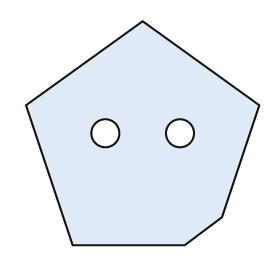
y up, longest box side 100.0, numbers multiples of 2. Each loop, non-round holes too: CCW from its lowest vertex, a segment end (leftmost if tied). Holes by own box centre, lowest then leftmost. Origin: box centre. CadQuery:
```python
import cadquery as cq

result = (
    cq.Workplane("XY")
    .moveTo(-30.0, -48.0)
    .lineTo(18.0, -48.0)
    .lineTo(34.0, -36.0)
    .lineTo(50.0, 12.0)
    .lineTo(0.0, 48.0)
    .lineTo(-50.0, 12.0)
    .close()
    .moveTo(-16.0, 0.0)
    .circle(6.0)
    .moveTo(16.0, 0.0)
    .circle(6.0)
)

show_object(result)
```